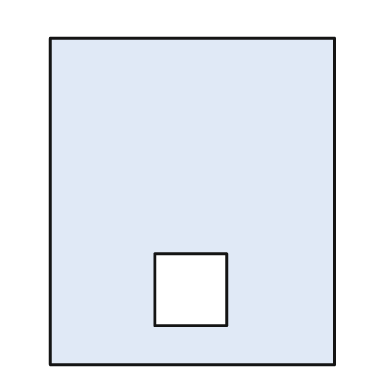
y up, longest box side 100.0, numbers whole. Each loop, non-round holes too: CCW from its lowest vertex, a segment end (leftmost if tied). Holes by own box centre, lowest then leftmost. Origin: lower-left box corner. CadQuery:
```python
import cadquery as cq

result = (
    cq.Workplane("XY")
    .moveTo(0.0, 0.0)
    .lineTo(87.0, 0.0)
    .lineTo(87.0, 100.0)
    .lineTo(0.0, 100.0)
    .close()
    .moveTo(32.0, 12.0)
    .lineTo(54.0, 12.0)
    .lineTo(54.0, 34.0)
    .lineTo(32.0, 34.0)
    .close()
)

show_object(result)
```